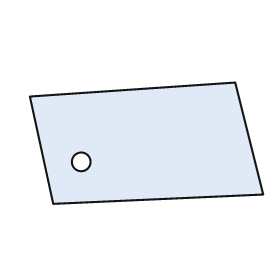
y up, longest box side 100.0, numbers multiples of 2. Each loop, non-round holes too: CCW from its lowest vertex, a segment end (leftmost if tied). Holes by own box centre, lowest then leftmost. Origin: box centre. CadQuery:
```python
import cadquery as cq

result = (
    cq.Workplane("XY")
    .moveTo(-40.0, -26.0)
    .lineTo(50.0, -22.0)
    .lineTo(38.0, 26.0)
    .lineTo(-50.0, 20.0)
    .close()
    .moveTo(-28.0, -8.0)
    .circle(4.0)
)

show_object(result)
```